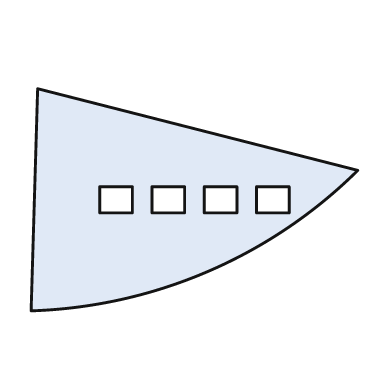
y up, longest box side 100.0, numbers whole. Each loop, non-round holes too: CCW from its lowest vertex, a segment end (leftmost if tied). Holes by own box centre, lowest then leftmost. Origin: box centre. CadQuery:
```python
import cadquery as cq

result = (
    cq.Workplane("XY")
    .moveTo(-50.0, -34.0)
    .threePointArc((4.0, -22.0), (50.0, 9.0))
    .lineTo(-48.0, 34.0)
    .close()
    .moveTo(-29.0, -4.0)
    .lineTo(-19.0, -4.0)
    .lineTo(-19.0, 4.0)
    .lineTo(-29.0, 4.0)
    .close()
    .moveTo(-13.0, -4.0)
    .lineTo(-3.0, -4.0)
    .lineTo(-3.0, 4.0)
    .lineTo(-13.0, 4.0)
    .close()
    .moveTo(3.0, -4.0)
    .lineTo(13.0, -4.0)
    .lineTo(13.0, 4.0)
    .lineTo(3.0, 4.0)
    .close()
    .moveTo(19.0, -4.0)
    .lineTo(29.0, -4.0)
    .lineTo(29.0, 4.0)
    .lineTo(19.0, 4.0)
    .close()
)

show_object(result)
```